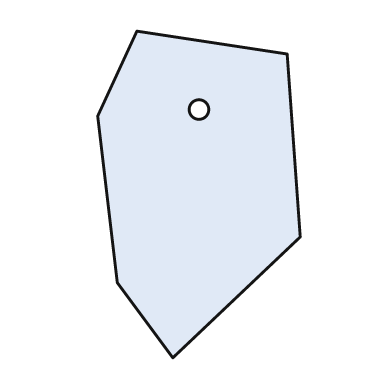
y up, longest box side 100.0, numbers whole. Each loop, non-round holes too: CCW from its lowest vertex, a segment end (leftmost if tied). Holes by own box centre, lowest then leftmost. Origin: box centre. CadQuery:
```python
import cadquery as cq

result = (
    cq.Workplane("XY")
    .moveTo(-8.0, -50.0)
    .lineTo(31.0, -13.0)
    .lineTo(27.0, 43.0)
    .lineTo(-19.0, 50.0)
    .lineTo(-31.0, 24.0)
    .lineTo(-25.0, -27.0)
    .close()
    .moveTo(0.0, 26.0)
    .circle(3.0)
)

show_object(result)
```